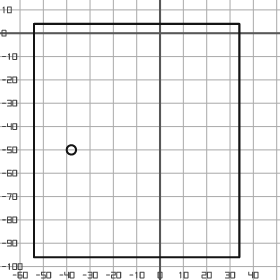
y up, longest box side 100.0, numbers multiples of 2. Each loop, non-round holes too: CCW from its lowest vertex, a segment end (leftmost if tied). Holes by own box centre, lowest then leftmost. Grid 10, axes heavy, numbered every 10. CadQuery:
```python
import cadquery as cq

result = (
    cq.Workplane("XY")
    .moveTo(-54.0, -96.0)
    .lineTo(34.0, -96.0)
    .lineTo(34.0, 4.0)
    .lineTo(-54.0, 4.0)
    .close()
    .moveTo(-38.0, -50.0)
    .circle(2.0)
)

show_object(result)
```